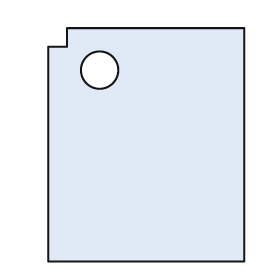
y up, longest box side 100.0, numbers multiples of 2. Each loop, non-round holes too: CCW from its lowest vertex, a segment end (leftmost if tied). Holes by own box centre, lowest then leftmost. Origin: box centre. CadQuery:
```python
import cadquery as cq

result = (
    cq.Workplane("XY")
    .moveTo(-42.0, -50.0)
    .lineTo(42.0, -50.0)
    .lineTo(42.0, 50.0)
    .lineTo(-34.0, 50.0)
    .lineTo(-34.0, 42.0)
    .lineTo(-42.0, 42.0)
    .close()
    .moveTo(-20.0, 32.0)
    .circle(8.0)
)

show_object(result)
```